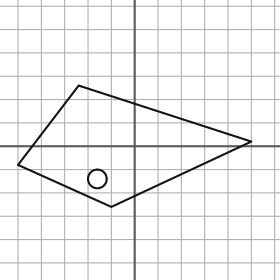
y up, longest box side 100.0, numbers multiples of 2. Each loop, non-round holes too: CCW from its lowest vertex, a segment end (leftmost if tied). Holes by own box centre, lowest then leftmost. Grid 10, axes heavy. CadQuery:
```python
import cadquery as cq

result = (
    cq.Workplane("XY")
    .moveTo(-10.0, -26.0)
    .lineTo(50.0, 2.0)
    .lineTo(-24.0, 26.0)
    .lineTo(-50.0, -8.0)
    .close()
    .moveTo(-16.0, -14.0)
    .circle(4.0)
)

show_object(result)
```